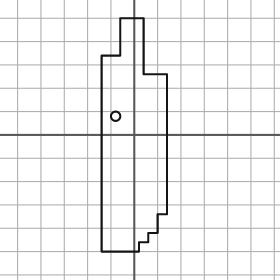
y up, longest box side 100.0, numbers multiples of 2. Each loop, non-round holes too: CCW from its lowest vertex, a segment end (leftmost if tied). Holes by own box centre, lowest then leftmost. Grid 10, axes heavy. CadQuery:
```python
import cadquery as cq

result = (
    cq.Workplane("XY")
    .moveTo(-14.0, -50.0)
    .lineTo(2.0, -50.0)
    .lineTo(2.0, -46.0)
    .lineTo(6.0, -46.0)
    .lineTo(6.0, -42.0)
    .lineTo(10.0, -42.0)
    .lineTo(10.0, -34.0)
    .lineTo(14.0, -34.0)
    .lineTo(14.0, 26.0)
    .lineTo(4.0, 26.0)
    .lineTo(4.0, 50.0)
    .lineTo(-6.0, 50.0)
    .lineTo(-6.0, 34.0)
    .lineTo(-14.0, 34.0)
    .close()
    .moveTo(-8.0, 8.0)
    .circle(2.0)
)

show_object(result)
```